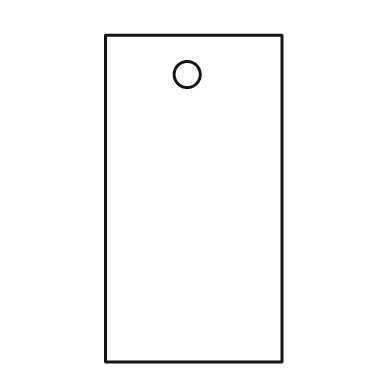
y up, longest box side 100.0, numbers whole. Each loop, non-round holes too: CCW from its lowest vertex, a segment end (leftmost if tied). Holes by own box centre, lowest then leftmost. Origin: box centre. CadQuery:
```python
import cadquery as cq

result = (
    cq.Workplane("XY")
    .moveTo(-27.0, -50.0)
    .lineTo(27.0, -50.0)
    .lineTo(27.0, 50.0)
    .lineTo(-27.0, 50.0)
    .close()
    .moveTo(-2.0, 38.0)
    .circle(4.0)
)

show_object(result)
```